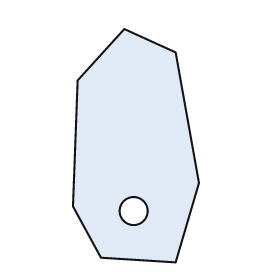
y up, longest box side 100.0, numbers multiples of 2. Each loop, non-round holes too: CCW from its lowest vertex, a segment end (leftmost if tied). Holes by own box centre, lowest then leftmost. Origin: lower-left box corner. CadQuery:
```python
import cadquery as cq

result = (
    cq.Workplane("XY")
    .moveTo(44.0, 0.0)
    .lineTo(54.0, 34.0)
    .lineTo(44.0, 90.0)
    .lineTo(22.0, 100.0)
    .lineTo(2.0, 78.0)
    .lineTo(0.0, 24.0)
    .lineTo(12.0, 2.0)
    .close()
    .moveTo(26.0, 22.0)
    .circle(6.0)
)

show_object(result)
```